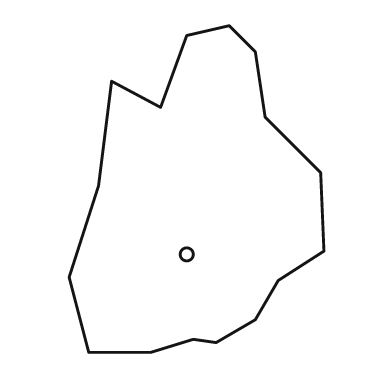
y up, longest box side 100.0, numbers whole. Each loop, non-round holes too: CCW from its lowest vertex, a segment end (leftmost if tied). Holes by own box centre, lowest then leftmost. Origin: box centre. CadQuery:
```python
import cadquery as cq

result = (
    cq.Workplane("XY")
    .moveTo(-33.0, -50.0)
    .lineTo(-14.0, -50.0)
    .lineTo(-1.0, -46.0)
    .lineTo(6.0, -47.0)
    .lineTo(18.0, -40.0)
    .lineTo(25.0, -28.0)
    .lineTo(39.0, -19.0)
    .lineTo(38.0, 5.0)
    .lineTo(21.0, 22.0)
    .lineTo(18.0, 42.0)
    .lineTo(10.0, 50.0)
    .lineTo(-3.0, 47.0)
    .lineTo(-11.0, 25.0)
    .lineTo(-26.0, 33.0)
    .lineTo(-30.0, 1.0)
    .lineTo(-39.0, -27.0)
    .close()
    .moveTo(-3.0, -20.0)
    .circle(2.0)
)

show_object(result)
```